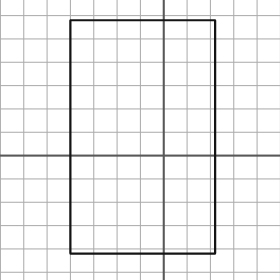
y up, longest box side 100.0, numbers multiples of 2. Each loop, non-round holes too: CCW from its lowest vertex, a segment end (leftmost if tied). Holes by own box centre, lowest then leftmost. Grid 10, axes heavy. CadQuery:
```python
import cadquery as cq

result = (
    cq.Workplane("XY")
    .moveTo(-40.0, -42.0)
    .lineTo(22.0, -42.0)
    .lineTo(22.0, 58.0)
    .lineTo(-40.0, 58.0)
    .close()
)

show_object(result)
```